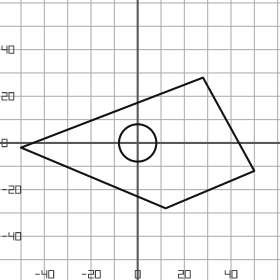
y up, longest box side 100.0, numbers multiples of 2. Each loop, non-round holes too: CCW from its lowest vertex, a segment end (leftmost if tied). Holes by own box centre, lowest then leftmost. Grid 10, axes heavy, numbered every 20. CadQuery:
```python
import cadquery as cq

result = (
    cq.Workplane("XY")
    .moveTo(12.0, -28.0)
    .lineTo(50.0, -12.0)
    .lineTo(28.0, 28.0)
    .lineTo(-50.0, -2.0)
    .close()
    .moveTo(0.0, 0.0)
    .circle(8.0)
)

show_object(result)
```